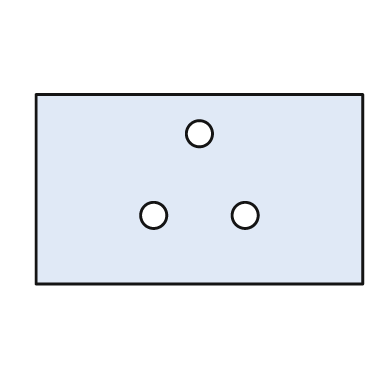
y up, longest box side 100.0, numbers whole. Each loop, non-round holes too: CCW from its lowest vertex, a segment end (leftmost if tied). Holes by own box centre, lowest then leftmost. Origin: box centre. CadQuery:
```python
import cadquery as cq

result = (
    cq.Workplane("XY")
    .moveTo(-50.0, -29.0)
    .lineTo(50.0, -29.0)
    .lineTo(50.0, 29.0)
    .lineTo(-50.0, 29.0)
    .close()
    .moveTo(-14.0, -8.0)
    .circle(4.0)
    .moveTo(14.0, -8.0)
    .circle(4.0)
    .moveTo(0.0, 17.0)
    .circle(4.0)
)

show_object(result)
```